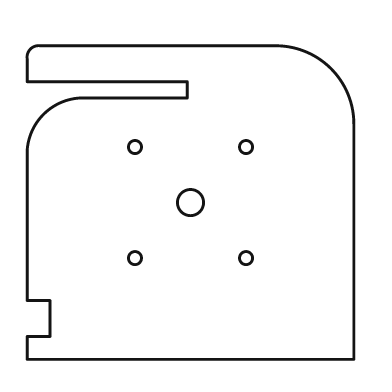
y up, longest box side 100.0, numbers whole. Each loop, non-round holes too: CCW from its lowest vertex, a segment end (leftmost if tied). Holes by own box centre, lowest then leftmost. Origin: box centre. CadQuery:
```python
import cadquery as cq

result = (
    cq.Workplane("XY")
    .moveTo(-50.0, -48.0)
    .lineTo(50.0, -48.0)
    .lineTo(50.0, 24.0)
    .threePointArc((43.0, 41.0), (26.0, 48.0))
    .lineTo(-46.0, 48.0)
    .threePointArc((-49.0, 47.0), (-50.0, 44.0))
    .lineTo(-50.0, 37.0)
    .lineTo(-1.0, 37.0)
    .lineTo(-1.0, 32.0)
    .lineTo(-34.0, 32.0)
    .threePointArc((-45.0, 27.0), (-50.0, 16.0))
    .lineTo(-50.0, -30.0)
    .lineTo(-43.0, -30.0)
    .lineTo(-43.0, -41.0)
    .lineTo(-50.0, -41.0)
    .close()
    .moveTo(-17.0, -17.0)
    .circle(2.0)
    .moveTo(17.0, -17.0)
    .circle(2.0)
    .moveTo(0.0, 0.0)
    .circle(4.0)
    .moveTo(-17.0, 17.0)
    .circle(2.0)
    .moveTo(17.0, 17.0)
    .circle(2.0)
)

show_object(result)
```